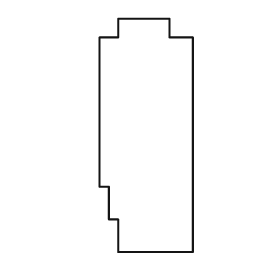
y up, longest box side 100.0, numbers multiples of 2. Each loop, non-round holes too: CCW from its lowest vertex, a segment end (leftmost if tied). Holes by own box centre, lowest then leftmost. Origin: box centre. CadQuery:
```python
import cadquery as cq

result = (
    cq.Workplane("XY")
    .moveTo(-12.0, -50.0)
    .lineTo(20.0, -50.0)
    .lineTo(20.0, 42.0)
    .lineTo(10.0, 42.0)
    .lineTo(10.0, 50.0)
    .lineTo(-12.0, 50.0)
    .lineTo(-12.0, 42.0)
    .lineTo(-20.0, 42.0)
    .lineTo(-20.0, -22.0)
    .lineTo(-16.0, -22.0)
    .lineTo(-16.0, -36.0)
    .lineTo(-12.0, -36.0)
    .close()
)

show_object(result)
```